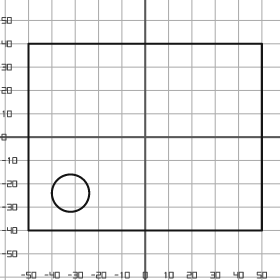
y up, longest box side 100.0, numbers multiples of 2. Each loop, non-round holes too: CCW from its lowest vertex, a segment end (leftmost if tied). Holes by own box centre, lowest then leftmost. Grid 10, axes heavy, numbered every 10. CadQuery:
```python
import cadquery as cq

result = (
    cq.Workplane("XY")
    .moveTo(-50.0, -40.0)
    .lineTo(50.0, -40.0)
    .lineTo(50.0, 40.0)
    .lineTo(-50.0, 40.0)
    .close()
    .moveTo(-32.0, -24.0)
    .circle(8.0)
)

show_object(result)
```